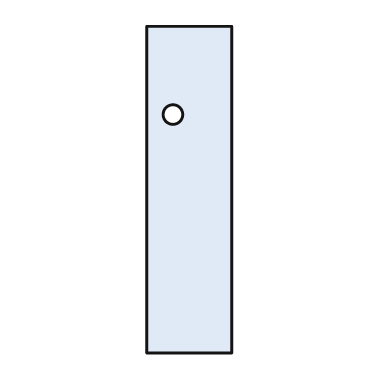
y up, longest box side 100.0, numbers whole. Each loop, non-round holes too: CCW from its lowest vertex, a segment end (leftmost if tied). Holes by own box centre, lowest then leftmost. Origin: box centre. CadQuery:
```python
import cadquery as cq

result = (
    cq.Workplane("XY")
    .moveTo(-13.0, -50.0)
    .lineTo(13.0, -50.0)
    .lineTo(13.0, 50.0)
    .lineTo(-13.0, 50.0)
    .close()
    .moveTo(-5.0, 23.0)
    .circle(3.0)
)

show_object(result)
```